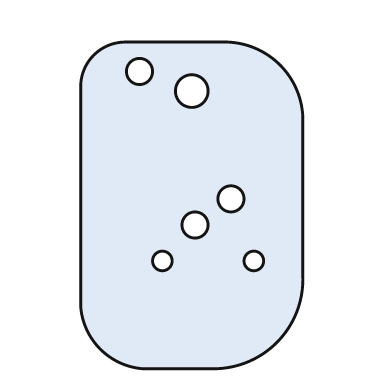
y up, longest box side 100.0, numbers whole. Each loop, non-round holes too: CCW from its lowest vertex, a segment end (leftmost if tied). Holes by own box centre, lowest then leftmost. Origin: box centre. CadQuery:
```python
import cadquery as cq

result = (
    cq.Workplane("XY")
    .moveTo(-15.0, -50.0)
    .lineTo(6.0, -50.0)
    .threePointArc((26.0, -42.0), (34.0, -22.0))
    .lineTo(34.0, 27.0)
    .threePointArc((27.0, 43.0), (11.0, 50.0))
    .lineTo(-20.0, 50.0)
    .threePointArc((-30.0, 46.0), (-34.0, 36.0))
    .lineTo(-34.0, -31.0)
    .threePointArc((-28.0, -44.0), (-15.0, -50.0))
    .close()
    .moveTo(-9.0, -17.0)
    .circle(3.0)
    .moveTo(19.0, -17.0)
    .circle(3.0)
    .moveTo(1.0, -6.0)
    .circle(4.0)
    .moveTo(12.0, 2.0)
    .circle(4.0)
    .moveTo(0.0, 35.0)
    .circle(5.0)
    .moveTo(-16.0, 41.0)
    .circle(4.0)
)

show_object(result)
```